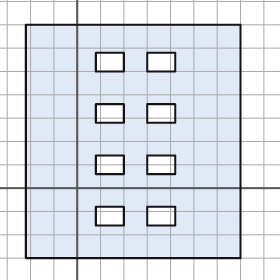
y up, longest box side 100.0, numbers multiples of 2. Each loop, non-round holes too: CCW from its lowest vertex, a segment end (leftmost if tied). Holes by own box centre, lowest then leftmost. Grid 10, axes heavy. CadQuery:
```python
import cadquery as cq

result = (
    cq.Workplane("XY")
    .moveTo(-22.0, -30.0)
    .lineTo(70.0, -30.0)
    .lineTo(70.0, 70.0)
    .lineTo(-22.0, 70.0)
    .close()
    .moveTo(8.0, -16.0)
    .lineTo(20.0, -16.0)
    .lineTo(20.0, -8.0)
    .lineTo(8.0, -8.0)
    .close()
    .moveTo(30.0, -16.0)
    .lineTo(42.0, -16.0)
    .lineTo(42.0, -8.0)
    .lineTo(30.0, -8.0)
    .close()
    .moveTo(8.0, 6.0)
    .lineTo(20.0, 6.0)
    .lineTo(20.0, 14.0)
    .lineTo(8.0, 14.0)
    .close()
    .moveTo(30.0, 6.0)
    .lineTo(42.0, 6.0)
    .lineTo(42.0, 14.0)
    .lineTo(30.0, 14.0)
    .close()
    .moveTo(8.0, 28.0)
    .lineTo(20.0, 28.0)
    .lineTo(20.0, 36.0)
    .lineTo(8.0, 36.0)
    .close()
    .moveTo(30.0, 28.0)
    .lineTo(42.0, 28.0)
    .lineTo(42.0, 36.0)
    .lineTo(30.0, 36.0)
    .close()
    .moveTo(8.0, 50.0)
    .lineTo(20.0, 50.0)
    .lineTo(20.0, 58.0)
    .lineTo(8.0, 58.0)
    .close()
    .moveTo(30.0, 50.0)
    .lineTo(42.0, 50.0)
    .lineTo(42.0, 58.0)
    .lineTo(30.0, 58.0)
    .close()
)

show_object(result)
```